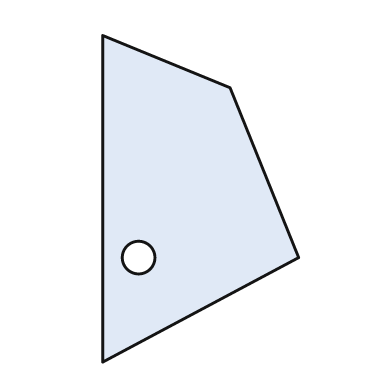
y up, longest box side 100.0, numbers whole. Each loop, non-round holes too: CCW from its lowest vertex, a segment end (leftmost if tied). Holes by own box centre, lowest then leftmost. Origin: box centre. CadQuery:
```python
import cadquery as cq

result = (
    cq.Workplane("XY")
    .moveTo(-30.0, -50.0)
    .lineTo(30.0, -18.0)
    .lineTo(9.0, 34.0)
    .lineTo(-30.0, 50.0)
    .close()
    .moveTo(-19.0, -18.0)
    .circle(5.0)
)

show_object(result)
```